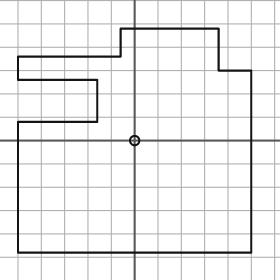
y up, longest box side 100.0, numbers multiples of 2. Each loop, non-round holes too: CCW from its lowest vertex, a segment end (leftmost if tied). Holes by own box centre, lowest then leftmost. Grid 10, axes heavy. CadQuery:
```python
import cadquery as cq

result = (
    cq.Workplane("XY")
    .moveTo(-50.0, -48.0)
    .lineTo(50.0, -48.0)
    .lineTo(50.0, 30.0)
    .lineTo(36.0, 30.0)
    .lineTo(36.0, 48.0)
    .lineTo(-6.0, 48.0)
    .lineTo(-6.0, 36.0)
    .lineTo(-50.0, 36.0)
    .lineTo(-50.0, 26.0)
    .lineTo(-16.0, 26.0)
    .lineTo(-16.0, 8.0)
    .lineTo(-50.0, 8.0)
    .close()
    .moveTo(0.0, 0.0)
    .circle(2.0)
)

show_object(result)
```